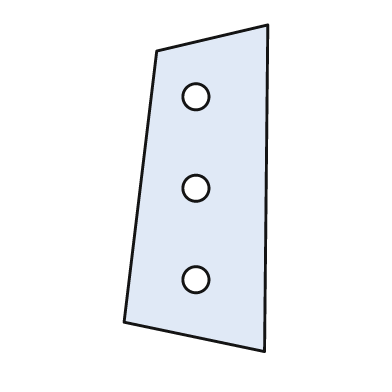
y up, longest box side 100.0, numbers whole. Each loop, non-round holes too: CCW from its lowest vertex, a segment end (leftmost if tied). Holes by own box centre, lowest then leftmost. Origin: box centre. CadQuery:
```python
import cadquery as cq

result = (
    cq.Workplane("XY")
    .moveTo(21.0, -50.0)
    .lineTo(22.0, 50.0)
    .lineTo(-12.0, 42.0)
    .lineTo(-22.0, -41.0)
    .close()
    .moveTo(0.0, -28.0)
    .circle(4.0)
    .moveTo(0.0, 0.0)
    .circle(4.0)
    .moveTo(0.0, 28.0)
    .circle(4.0)
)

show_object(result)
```